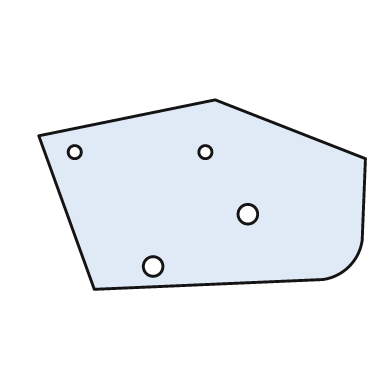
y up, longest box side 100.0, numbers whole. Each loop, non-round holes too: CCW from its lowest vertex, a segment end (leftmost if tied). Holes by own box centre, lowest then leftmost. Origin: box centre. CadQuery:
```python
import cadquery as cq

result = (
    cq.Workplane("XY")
    .moveTo(-33.0, -29.0)
    .lineTo(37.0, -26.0)
    .threePointArc((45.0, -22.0), (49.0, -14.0))
    .lineTo(50.0, 11.0)
    .lineTo(4.0, 29.0)
    .lineTo(-50.0, 18.0)
    .close()
    .moveTo(-15.0, -22.0)
    .circle(3.0)
    .moveTo(14.0, -6.0)
    .circle(3.0)
    .moveTo(-39.0, 13.0)
    .circle(2.0)
    .moveTo(1.0, 13.0)
    .circle(2.0)
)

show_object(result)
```